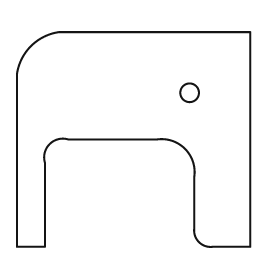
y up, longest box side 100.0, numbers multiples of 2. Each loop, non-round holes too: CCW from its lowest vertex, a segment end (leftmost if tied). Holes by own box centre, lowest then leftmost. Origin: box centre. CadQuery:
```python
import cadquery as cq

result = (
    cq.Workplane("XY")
    .moveTo(-50.0, -46.0)
    .lineTo(-38.0, -46.0)
    .lineTo(-38.0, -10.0)
    .threePointArc((-36.0, -2.0), (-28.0, 0.0))
    .lineTo(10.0, 0.0)
    .threePointArc((22.0, -4.0), (26.0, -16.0))
    .lineTo(26.0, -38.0)
    .threePointArc((28.0, -44.0), (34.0, -46.0))
    .lineTo(50.0, -46.0)
    .lineTo(50.0, 46.0)
    .lineTo(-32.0, 46.0)
    .threePointArc((-44.0, 40.0), (-50.0, 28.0))
    .close()
    .moveTo(24.0, 20.0)
    .circle(4.0)
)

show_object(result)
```